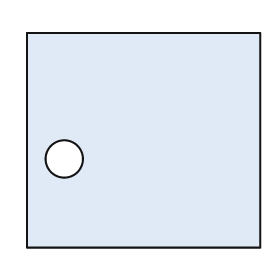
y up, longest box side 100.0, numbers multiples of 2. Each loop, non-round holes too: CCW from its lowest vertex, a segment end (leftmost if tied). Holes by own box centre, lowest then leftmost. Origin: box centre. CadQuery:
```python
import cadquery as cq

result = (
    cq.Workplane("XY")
    .moveTo(-50.0, -46.0)
    .lineTo(50.0, -46.0)
    .lineTo(50.0, 46.0)
    .lineTo(-50.0, 46.0)
    .close()
    .moveTo(-34.0, -8.0)
    .circle(8.0)
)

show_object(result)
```